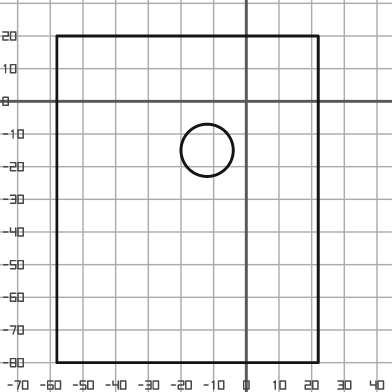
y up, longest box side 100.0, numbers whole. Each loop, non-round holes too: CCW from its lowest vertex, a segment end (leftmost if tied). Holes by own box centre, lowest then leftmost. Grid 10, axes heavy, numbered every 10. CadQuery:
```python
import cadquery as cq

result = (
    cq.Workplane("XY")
    .moveTo(-58.0, -80.0)
    .lineTo(22.0, -80.0)
    .lineTo(22.0, 20.0)
    .lineTo(-58.0, 20.0)
    .close()
    .moveTo(-12.0, -15.0)
    .circle(8.0)
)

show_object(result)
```